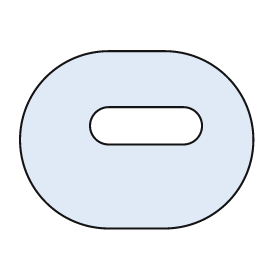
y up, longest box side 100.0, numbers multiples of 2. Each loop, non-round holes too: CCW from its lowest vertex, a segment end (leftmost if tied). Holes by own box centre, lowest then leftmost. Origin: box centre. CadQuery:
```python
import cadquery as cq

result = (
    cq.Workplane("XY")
    .moveTo(-12.0, -38.0)
    .lineTo(12.0, -38.0)
    .threePointArc((50.0, 0.0), (12.0, 38.0))
    .lineTo(-12.0, 38.0)
    .threePointArc((-50.0, 0.0), (-12.0, -38.0))
    .close()
    .moveTo(-12.0, -2.0)
    .lineTo(20.0, -2.0)
    .threePointArc((28.0, 6.0), (20.0, 14.0))
    .lineTo(-12.0, 14.0)
    .threePointArc((-20.0, 6.0), (-12.0, -2.0))
    .close()
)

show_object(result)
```